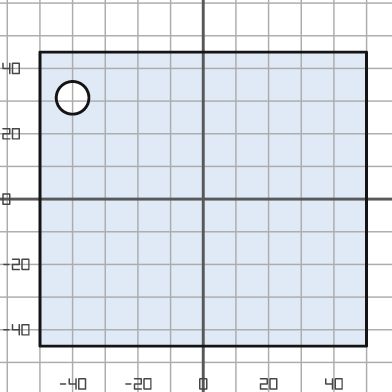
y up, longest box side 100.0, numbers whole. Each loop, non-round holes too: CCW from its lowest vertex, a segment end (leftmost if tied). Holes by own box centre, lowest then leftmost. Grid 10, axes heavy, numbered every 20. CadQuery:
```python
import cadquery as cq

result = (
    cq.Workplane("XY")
    .moveTo(-50.0, -45.0)
    .lineTo(50.0, -45.0)
    .lineTo(50.0, 45.0)
    .lineTo(-50.0, 45.0)
    .close()
    .moveTo(-40.0, 31.0)
    .circle(5.0)
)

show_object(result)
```